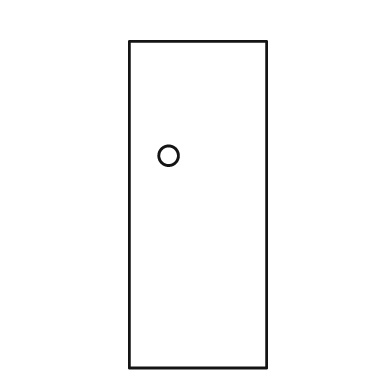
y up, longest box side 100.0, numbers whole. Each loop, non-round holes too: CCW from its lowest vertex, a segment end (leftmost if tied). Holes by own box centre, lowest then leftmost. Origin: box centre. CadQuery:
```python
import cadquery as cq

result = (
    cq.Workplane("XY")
    .moveTo(-21.0, -50.0)
    .lineTo(21.0, -50.0)
    .lineTo(21.0, 50.0)
    .lineTo(-21.0, 50.0)
    .close()
    .moveTo(-9.0, 15.0)
    .circle(3.0)
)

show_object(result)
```